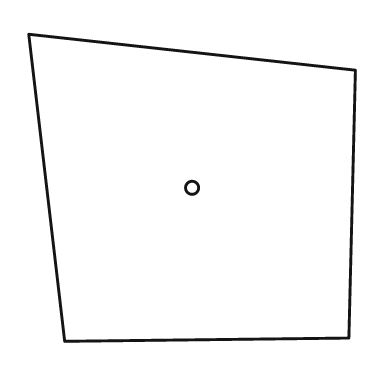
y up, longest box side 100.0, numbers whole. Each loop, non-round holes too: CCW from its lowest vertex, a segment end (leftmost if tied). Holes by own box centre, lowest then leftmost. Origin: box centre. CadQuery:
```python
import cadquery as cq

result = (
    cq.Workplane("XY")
    .moveTo(-39.0, -47.0)
    .lineTo(48.0, -46.0)
    .lineTo(50.0, 36.0)
    .lineTo(-50.0, 47.0)
    .close()
    .moveTo(0.0, 0.0)
    .circle(2.0)
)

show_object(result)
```